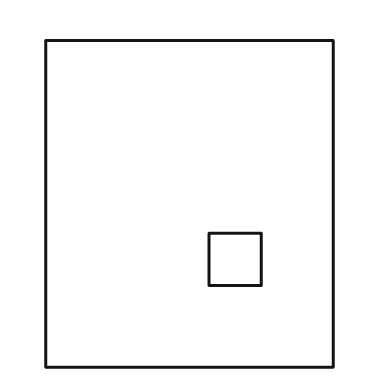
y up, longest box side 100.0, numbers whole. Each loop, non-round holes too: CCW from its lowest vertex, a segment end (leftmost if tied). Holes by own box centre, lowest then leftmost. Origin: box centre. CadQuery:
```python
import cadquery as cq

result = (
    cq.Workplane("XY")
    .moveTo(-44.0, -50.0)
    .lineTo(44.0, -50.0)
    .lineTo(44.0, 50.0)
    .lineTo(-44.0, 50.0)
    .close()
    .moveTo(6.0, -25.0)
    .lineTo(22.0, -25.0)
    .lineTo(22.0, -9.0)
    .lineTo(6.0, -9.0)
    .close()
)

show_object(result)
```